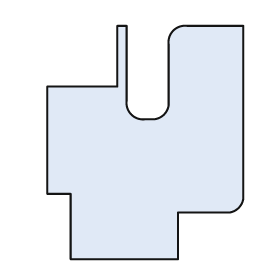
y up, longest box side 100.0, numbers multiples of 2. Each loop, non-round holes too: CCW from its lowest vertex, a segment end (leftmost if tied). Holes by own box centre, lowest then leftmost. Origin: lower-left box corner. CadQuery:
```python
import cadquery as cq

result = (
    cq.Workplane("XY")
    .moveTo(10.0, 0.0)
    .lineTo(56.0, 0.0)
    .lineTo(56.0, 20.0)
    .lineTo(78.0, 20.0)
    .threePointArc((82.0, 22.0), (84.0, 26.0))
    .lineTo(84.0, 100.0)
    .lineTo(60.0, 100.0)
    .threePointArc((54.0, 98.0), (52.0, 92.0))
    .lineTo(52.0, 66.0)
    .threePointArc((50.0, 62.0), (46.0, 60.0))
    .lineTo(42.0, 60.0)
    .threePointArc((36.0, 62.0), (34.0, 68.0))
    .lineTo(34.0, 100.0)
    .lineTo(30.0, 100.0)
    .lineTo(30.0, 74.0)
    .lineTo(0.0, 74.0)
    .lineTo(0.0, 28.0)
    .lineTo(10.0, 28.0)
    .close()
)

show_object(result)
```